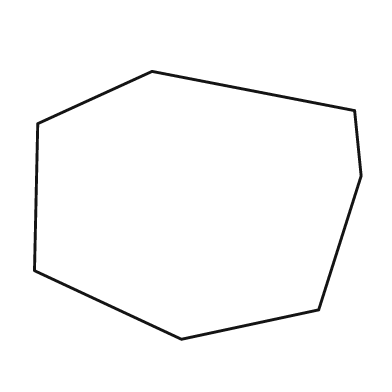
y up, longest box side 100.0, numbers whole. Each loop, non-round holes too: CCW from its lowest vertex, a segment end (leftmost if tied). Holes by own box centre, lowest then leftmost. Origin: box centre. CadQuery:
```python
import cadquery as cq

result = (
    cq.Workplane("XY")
    .moveTo(-5.0, -41.0)
    .lineTo(37.0, -32.0)
    .lineTo(50.0, 9.0)
    .lineTo(48.0, 29.0)
    .lineTo(-14.0, 41.0)
    .lineTo(-49.0, 25.0)
    .lineTo(-50.0, -20.0)
    .close()
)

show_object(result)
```